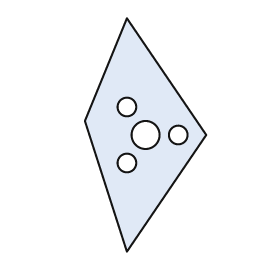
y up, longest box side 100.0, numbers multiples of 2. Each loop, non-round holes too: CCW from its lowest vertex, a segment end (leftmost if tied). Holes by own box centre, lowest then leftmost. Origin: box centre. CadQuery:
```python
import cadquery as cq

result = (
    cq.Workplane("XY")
    .moveTo(-8.0, -50.0)
    .lineTo(26.0, 0.0)
    .lineTo(-8.0, 50.0)
    .lineTo(-26.0, 6.0)
    .close()
    .moveTo(-8.0, -12.0)
    .circle(4.0)
    .moveTo(0.0, 0.0)
    .circle(6.0)
    .moveTo(14.0, 0.0)
    .circle(4.0)
    .moveTo(-8.0, 12.0)
    .circle(4.0)
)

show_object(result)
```